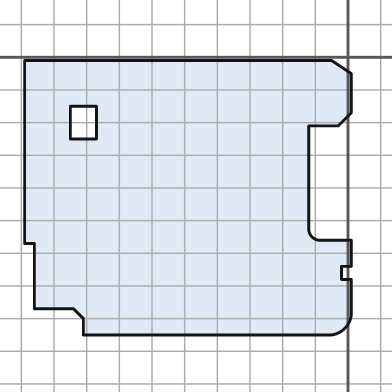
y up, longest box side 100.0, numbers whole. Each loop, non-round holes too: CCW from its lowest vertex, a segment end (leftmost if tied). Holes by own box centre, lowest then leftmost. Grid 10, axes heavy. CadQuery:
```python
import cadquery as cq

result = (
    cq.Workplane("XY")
    .moveTo(-81.0, -85.0)
    .lineTo(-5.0, -85.0)
    .threePointArc((-1.0, -83.0), (1.0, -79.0))
    .lineTo(1.0, -68.0)
    .lineTo(-2.0, -68.0)
    .lineTo(-2.0, -64.0)
    .lineTo(1.0, -64.0)
    .lineTo(1.0, -56.0)
    .lineTo(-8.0, -56.0)
    .threePointArc((-11.0, -55.0), (-12.0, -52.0))
    .lineTo(-12.0, -21.0)
    .lineTo(-3.0, -21.0)
    .lineTo(1.0, -17.0)
    .lineTo(1.0, -5.0)
    .lineTo(-5.0, -1.0)
    .lineTo(-99.0, -1.0)
    .lineTo(-99.0, -57.0)
    .lineTo(-96.0, -57.0)
    .lineTo(-96.0, -77.0)
    .lineTo(-84.0, -77.0)
    .lineTo(-81.0, -80.0)
    .close()
    .moveTo(-85.0, -25.0)
    .lineTo(-77.0, -25.0)
    .lineTo(-77.0, -15.0)
    .lineTo(-85.0, -15.0)
    .close()
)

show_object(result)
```